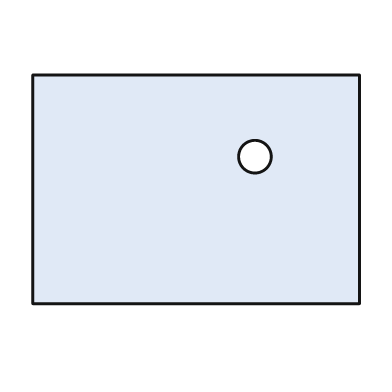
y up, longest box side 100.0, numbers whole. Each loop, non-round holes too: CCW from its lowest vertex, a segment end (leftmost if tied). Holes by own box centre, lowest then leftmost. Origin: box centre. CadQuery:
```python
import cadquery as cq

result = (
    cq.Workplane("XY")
    .moveTo(-50.0, -35.0)
    .lineTo(50.0, -35.0)
    .lineTo(50.0, 35.0)
    .lineTo(-50.0, 35.0)
    .close()
    .moveTo(18.0, 10.0)
    .circle(5.0)
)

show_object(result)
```